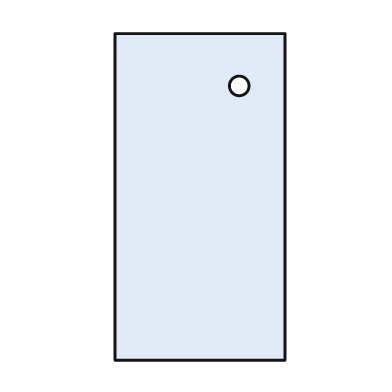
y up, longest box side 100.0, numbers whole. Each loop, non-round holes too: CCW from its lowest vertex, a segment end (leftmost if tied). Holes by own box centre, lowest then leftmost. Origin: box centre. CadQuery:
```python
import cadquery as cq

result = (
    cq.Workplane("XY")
    .moveTo(-26.0, -50.0)
    .lineTo(26.0, -50.0)
    .lineTo(26.0, 50.0)
    .lineTo(-26.0, 50.0)
    .close()
    .moveTo(12.0, 34.0)
    .circle(3.0)
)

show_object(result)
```